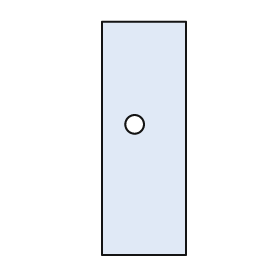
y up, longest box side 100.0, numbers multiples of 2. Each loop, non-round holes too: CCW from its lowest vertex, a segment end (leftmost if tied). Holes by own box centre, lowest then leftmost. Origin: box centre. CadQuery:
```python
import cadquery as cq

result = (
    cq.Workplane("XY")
    .moveTo(-18.0, -50.0)
    .lineTo(18.0, -50.0)
    .lineTo(18.0, 50.0)
    .lineTo(-18.0, 50.0)
    .close()
    .moveTo(-4.0, 6.0)
    .circle(4.0)
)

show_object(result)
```